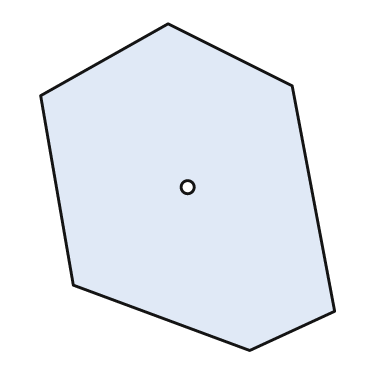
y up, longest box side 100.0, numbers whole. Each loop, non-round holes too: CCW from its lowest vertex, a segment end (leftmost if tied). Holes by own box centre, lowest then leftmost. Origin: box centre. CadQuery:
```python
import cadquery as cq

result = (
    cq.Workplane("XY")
    .moveTo(19.0, -50.0)
    .lineTo(45.0, -38.0)
    .lineTo(32.0, 31.0)
    .lineTo(-6.0, 50.0)
    .lineTo(-45.0, 28.0)
    .lineTo(-35.0, -30.0)
    .close()
    .moveTo(0.0, 0.0)
    .circle(2.0)
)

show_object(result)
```